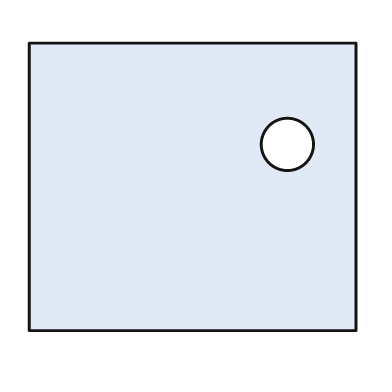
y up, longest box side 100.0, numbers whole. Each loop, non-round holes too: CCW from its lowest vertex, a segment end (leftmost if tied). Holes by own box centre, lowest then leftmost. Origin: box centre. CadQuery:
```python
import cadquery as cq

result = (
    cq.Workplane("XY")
    .moveTo(-50.0, -44.0)
    .lineTo(50.0, -44.0)
    .lineTo(50.0, 44.0)
    .lineTo(-50.0, 44.0)
    .close()
    .moveTo(29.0, 13.0)
    .circle(8.0)
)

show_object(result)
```